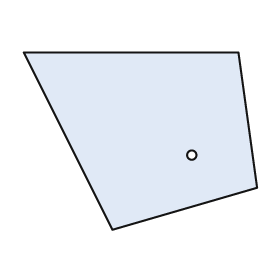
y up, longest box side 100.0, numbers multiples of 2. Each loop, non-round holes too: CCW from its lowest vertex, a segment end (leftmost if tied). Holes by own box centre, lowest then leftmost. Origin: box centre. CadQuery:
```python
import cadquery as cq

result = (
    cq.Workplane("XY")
    .moveTo(-12.0, -38.0)
    .lineTo(50.0, -20.0)
    .lineTo(42.0, 38.0)
    .lineTo(-50.0, 38.0)
    .close()
    .moveTo(22.0, -6.0)
    .circle(2.0)
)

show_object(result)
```